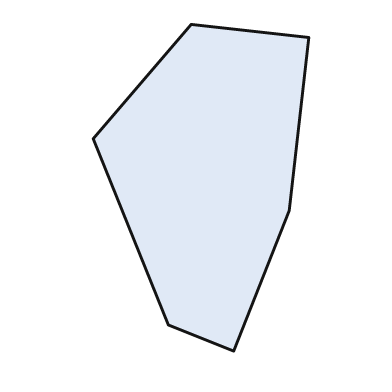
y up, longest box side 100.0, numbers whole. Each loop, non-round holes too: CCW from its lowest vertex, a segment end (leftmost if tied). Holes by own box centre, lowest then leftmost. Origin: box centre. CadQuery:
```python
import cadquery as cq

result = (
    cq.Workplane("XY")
    .moveTo(10.0, -50.0)
    .lineTo(27.0, -7.0)
    .lineTo(33.0, 46.0)
    .lineTo(-3.0, 50.0)
    .lineTo(-33.0, 15.0)
    .lineTo(-10.0, -42.0)
    .close()
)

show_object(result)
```